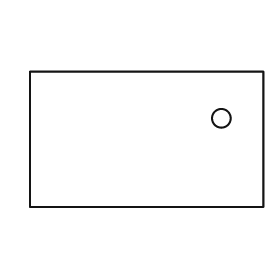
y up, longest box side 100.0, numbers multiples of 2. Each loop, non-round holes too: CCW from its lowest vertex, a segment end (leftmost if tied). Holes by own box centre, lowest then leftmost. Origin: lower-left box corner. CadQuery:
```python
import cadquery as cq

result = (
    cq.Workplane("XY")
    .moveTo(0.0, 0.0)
    .lineTo(100.0, 0.0)
    .lineTo(100.0, 58.0)
    .lineTo(0.0, 58.0)
    .close()
    .moveTo(82.0, 38.0)
    .circle(4.0)
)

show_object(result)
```